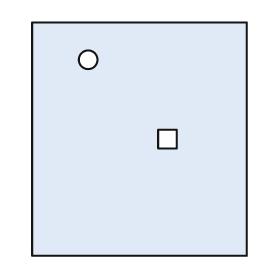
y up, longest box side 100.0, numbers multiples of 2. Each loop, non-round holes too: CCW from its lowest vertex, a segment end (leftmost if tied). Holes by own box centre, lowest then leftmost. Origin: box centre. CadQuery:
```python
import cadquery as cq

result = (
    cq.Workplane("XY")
    .moveTo(-46.0, -50.0)
    .lineTo(46.0, -50.0)
    .lineTo(46.0, 50.0)
    .lineTo(-46.0, 50.0)
    .close()
    .moveTo(8.0, -4.0)
    .lineTo(16.0, -4.0)
    .lineTo(16.0, 4.0)
    .lineTo(8.0, 4.0)
    .close()
    .moveTo(-22.0, 34.0)
    .circle(4.0)
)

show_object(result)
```